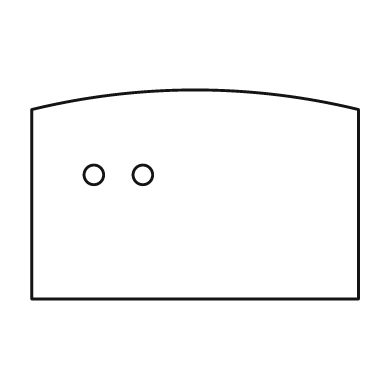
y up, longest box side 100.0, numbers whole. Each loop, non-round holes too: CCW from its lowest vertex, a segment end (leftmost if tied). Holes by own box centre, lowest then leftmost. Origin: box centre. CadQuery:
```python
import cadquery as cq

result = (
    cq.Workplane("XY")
    .moveTo(-50.0, -32.0)
    .lineTo(50.0, -32.0)
    .lineTo(50.0, 26.0)
    .threePointArc((0.0, 32.0), (-50.0, 26.0))
    .close()
    .moveTo(-31.0, 6.0)
    .circle(3.0)
    .moveTo(-16.0, 6.0)
    .circle(3.0)
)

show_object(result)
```